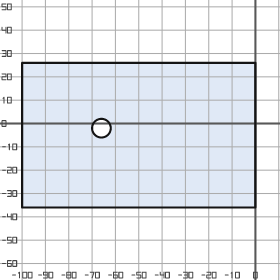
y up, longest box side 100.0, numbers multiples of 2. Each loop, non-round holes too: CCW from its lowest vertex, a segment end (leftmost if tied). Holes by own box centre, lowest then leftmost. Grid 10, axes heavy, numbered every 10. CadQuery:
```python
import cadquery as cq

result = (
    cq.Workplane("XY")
    .moveTo(-100.0, -36.0)
    .lineTo(0.0, -36.0)
    .lineTo(0.0, 26.0)
    .lineTo(-100.0, 26.0)
    .close()
    .moveTo(-66.0, -2.0)
    .circle(4.0)
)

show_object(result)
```